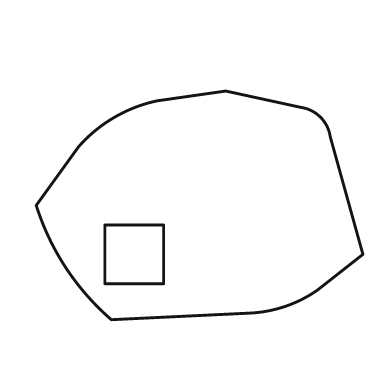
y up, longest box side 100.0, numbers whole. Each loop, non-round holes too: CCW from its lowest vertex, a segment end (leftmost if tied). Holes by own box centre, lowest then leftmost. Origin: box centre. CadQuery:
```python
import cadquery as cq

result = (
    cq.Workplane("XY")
    .moveTo(-27.0, -35.0)
    .lineTo(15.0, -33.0)
    .threePointArc((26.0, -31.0), (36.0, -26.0))
    .lineTo(50.0, -15.0)
    .lineTo(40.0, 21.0)
    .threePointArc((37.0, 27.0), (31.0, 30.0))
    .lineTo(8.0, 35.0)
    .lineTo(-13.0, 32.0)
    .threePointArc((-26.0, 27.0), (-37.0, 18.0))
    .lineTo(-50.0, 0.0)
    .threePointArc((-41.0, -19.0), (-27.0, -35.0))
    .close()
    .moveTo(-29.0, -24.0)
    .lineTo(-11.0, -24.0)
    .lineTo(-11.0, -6.0)
    .lineTo(-29.0, -6.0)
    .close()
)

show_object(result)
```